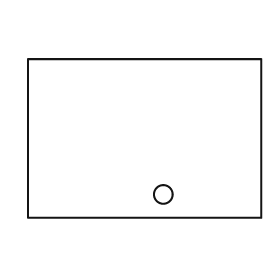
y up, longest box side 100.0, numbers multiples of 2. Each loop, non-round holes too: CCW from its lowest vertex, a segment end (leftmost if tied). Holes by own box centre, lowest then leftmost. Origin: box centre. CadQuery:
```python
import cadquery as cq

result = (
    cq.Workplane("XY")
    .moveTo(-50.0, -34.0)
    .lineTo(50.0, -34.0)
    .lineTo(50.0, 34.0)
    .lineTo(-50.0, 34.0)
    .close()
    .moveTo(8.0, -24.0)
    .circle(4.0)
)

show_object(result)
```